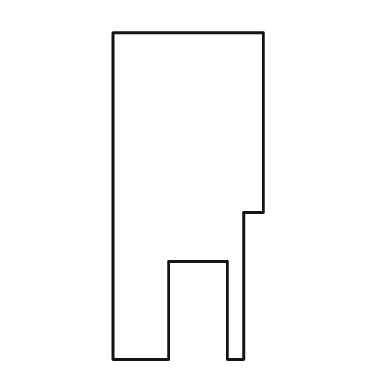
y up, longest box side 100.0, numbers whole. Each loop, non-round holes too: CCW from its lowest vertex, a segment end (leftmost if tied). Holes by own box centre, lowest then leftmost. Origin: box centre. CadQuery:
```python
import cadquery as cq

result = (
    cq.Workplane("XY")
    .moveTo(-23.0, -50.0)
    .lineTo(-6.0, -50.0)
    .lineTo(-6.0, -20.0)
    .lineTo(12.0, -20.0)
    .lineTo(12.0, -50.0)
    .lineTo(17.0, -50.0)
    .lineTo(17.0, -5.0)
    .lineTo(23.0, -5.0)
    .lineTo(23.0, 50.0)
    .lineTo(-23.0, 50.0)
    .close()
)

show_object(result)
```